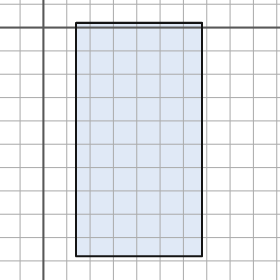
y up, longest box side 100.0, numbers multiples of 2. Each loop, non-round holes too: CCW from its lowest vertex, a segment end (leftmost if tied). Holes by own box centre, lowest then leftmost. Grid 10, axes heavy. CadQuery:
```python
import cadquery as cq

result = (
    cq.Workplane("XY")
    .moveTo(14.0, -98.0)
    .lineTo(68.0, -98.0)
    .lineTo(68.0, 2.0)
    .lineTo(14.0, 2.0)
    .close()
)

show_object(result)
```